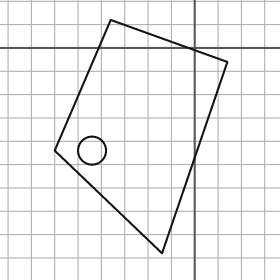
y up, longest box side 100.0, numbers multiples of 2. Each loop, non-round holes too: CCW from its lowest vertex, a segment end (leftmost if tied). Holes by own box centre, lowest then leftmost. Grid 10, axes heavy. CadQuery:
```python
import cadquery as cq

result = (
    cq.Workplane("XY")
    .moveTo(-14.0, -88.0)
    .lineTo(14.0, -6.0)
    .lineTo(-36.0, 12.0)
    .lineTo(-60.0, -44.0)
    .close()
    .moveTo(-44.0, -44.0)
    .circle(6.0)
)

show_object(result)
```